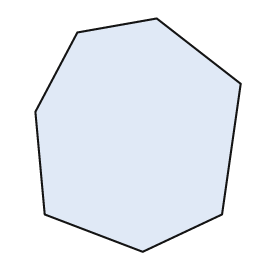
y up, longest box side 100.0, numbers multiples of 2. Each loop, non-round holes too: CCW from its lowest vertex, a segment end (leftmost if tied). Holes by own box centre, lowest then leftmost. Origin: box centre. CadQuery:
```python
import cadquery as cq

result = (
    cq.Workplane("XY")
    .moveTo(2.0, -50.0)
    .lineTo(36.0, -34.0)
    .lineTo(44.0, 22.0)
    .lineTo(8.0, 50.0)
    .lineTo(-26.0, 44.0)
    .lineTo(-44.0, 10.0)
    .lineTo(-40.0, -34.0)
    .close()
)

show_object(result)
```